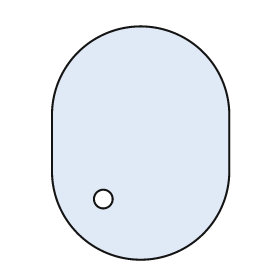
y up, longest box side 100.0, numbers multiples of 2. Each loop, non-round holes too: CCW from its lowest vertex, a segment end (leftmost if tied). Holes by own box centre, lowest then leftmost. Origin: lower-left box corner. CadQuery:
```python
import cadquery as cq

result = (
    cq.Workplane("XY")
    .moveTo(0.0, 38.0)
    .threePointArc((38.0, 0.0), (76.0, 38.0))
    .lineTo(76.0, 62.0)
    .threePointArc((38.0, 100.0), (0.0, 62.0))
    .close()
    .moveTo(22.0, 26.0)
    .circle(4.0)
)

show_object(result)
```